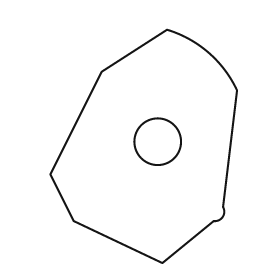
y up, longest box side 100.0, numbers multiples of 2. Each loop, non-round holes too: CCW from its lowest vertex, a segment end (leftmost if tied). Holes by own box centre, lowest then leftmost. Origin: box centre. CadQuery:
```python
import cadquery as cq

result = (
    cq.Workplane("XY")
    .moveTo(8.0, -50.0)
    .lineTo(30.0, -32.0)
    .threePointArc((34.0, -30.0), (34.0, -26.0))
    .lineTo(40.0, 24.0)
    .threePointArc((28.0, 40.0), (10.0, 50.0))
    .lineTo(-18.0, 32.0)
    .lineTo(-40.0, -12.0)
    .lineTo(-30.0, -32.0)
    .close()
    .moveTo(6.0, 2.0)
    .circle(10.0)
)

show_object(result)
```